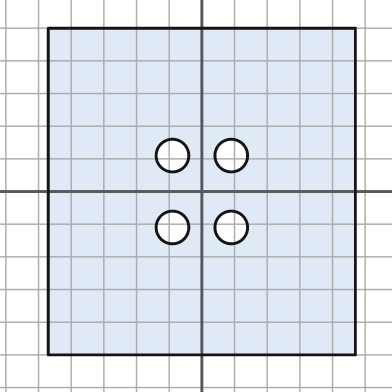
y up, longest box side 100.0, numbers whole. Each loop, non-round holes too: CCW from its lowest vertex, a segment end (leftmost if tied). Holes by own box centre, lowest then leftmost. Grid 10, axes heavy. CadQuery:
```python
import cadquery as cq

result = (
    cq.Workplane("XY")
    .moveTo(-47.0, -50.0)
    .lineTo(47.0, -50.0)
    .lineTo(47.0, 50.0)
    .lineTo(-47.0, 50.0)
    .close()
    .moveTo(-9.0, -11.0)
    .circle(5.0)
    .moveTo(9.0, -11.0)
    .circle(5.0)
    .moveTo(-9.0, 11.0)
    .circle(5.0)
    .moveTo(9.0, 11.0)
    .circle(5.0)
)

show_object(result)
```